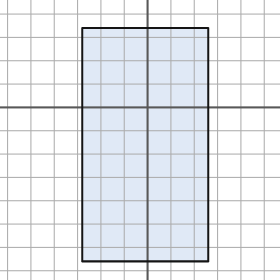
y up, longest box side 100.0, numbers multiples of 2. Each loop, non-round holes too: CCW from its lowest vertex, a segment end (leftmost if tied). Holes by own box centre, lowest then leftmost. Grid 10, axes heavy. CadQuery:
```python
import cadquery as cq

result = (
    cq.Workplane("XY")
    .moveTo(-28.0, -66.0)
    .lineTo(26.0, -66.0)
    .lineTo(26.0, 34.0)
    .lineTo(-28.0, 34.0)
    .close()
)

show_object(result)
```